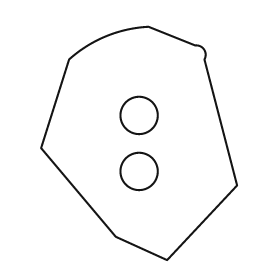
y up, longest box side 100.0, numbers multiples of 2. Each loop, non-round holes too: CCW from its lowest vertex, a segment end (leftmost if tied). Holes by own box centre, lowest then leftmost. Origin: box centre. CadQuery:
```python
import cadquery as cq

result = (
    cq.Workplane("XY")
    .moveTo(12.0, -50.0)
    .lineTo(42.0, -18.0)
    .lineTo(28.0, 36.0)
    .threePointArc((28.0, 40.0), (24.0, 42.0))
    .lineTo(4.0, 50.0)
    .threePointArc((-14.0, 46.0), (-30.0, 36.0))
    .lineTo(-42.0, -2.0)
    .lineTo(-10.0, -40.0)
    .close()
    .moveTo(0.0, -12.0)
    .circle(8.0)
    .moveTo(0.0, 12.0)
    .circle(8.0)
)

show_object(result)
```